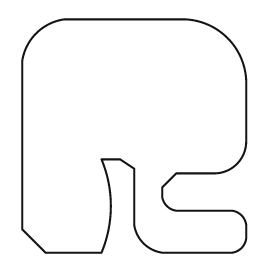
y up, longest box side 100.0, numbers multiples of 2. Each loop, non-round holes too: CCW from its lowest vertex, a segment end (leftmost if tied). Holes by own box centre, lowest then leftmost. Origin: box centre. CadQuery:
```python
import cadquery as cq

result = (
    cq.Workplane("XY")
    .moveTo(-38.0, -50.0)
    .lineTo(-14.0, -50.0)
    .threePointArc((-10.0, -30.0), (-14.0, -10.0))
    .lineTo(-6.0, -10.0)
    .lineTo(0.0, -14.0)
    .lineTo(0.0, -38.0)
    .threePointArc((4.0, -46.0), (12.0, -50.0))
    .lineTo(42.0, -50.0)
    .threePointArc((46.0, -48.0), (48.0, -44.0))
    .lineTo(48.0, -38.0)
    .threePointArc((46.0, -34.0), (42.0, -32.0))
    .lineTo(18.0, -32.0)
    .threePointArc((14.0, -30.0), (12.0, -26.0))
    .lineTo(12.0, -22.0)
    .lineTo(18.0, -16.0)
    .lineTo(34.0, -16.0)
    .threePointArc((44.0, -12.0), (48.0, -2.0))
    .lineTo(48.0, 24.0)
    .threePointArc((40.0, 42.0), (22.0, 50.0))
    .lineTo(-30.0, 50.0)
    .threePointArc((-42.0, 44.0), (-48.0, 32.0))
    .lineTo(-48.0, -40.0)
    .close()
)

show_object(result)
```